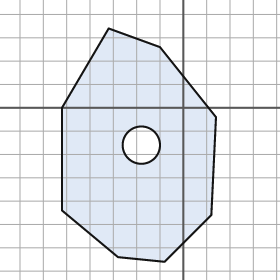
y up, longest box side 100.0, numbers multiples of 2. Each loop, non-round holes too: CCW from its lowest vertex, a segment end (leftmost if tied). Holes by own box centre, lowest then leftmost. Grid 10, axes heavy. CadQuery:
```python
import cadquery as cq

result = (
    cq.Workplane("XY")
    .moveTo(-8.0, -66.0)
    .lineTo(12.0, -46.0)
    .lineTo(14.0, -4.0)
    .lineTo(-10.0, 26.0)
    .lineTo(-32.0, 34.0)
    .lineTo(-52.0, 0.0)
    .lineTo(-52.0, -44.0)
    .lineTo(-28.0, -64.0)
    .close()
    .moveTo(-18.0, -16.0)
    .circle(8.0)
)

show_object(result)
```